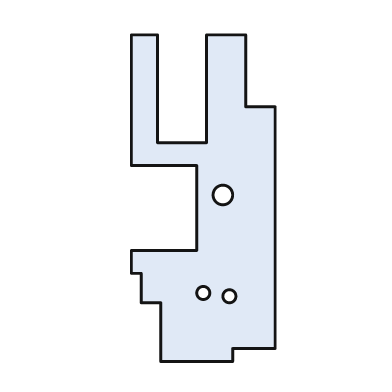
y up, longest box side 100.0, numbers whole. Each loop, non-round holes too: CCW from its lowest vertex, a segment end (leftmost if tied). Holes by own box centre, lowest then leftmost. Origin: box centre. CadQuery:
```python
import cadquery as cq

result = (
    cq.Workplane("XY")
    .moveTo(-13.0, -50.0)
    .lineTo(9.0, -50.0)
    .lineTo(9.0, -46.0)
    .lineTo(22.0, -46.0)
    .lineTo(22.0, 28.0)
    .lineTo(13.0, 28.0)
    .lineTo(13.0, 50.0)
    .lineTo(1.0, 50.0)
    .lineTo(1.0, 17.0)
    .lineTo(-14.0, 17.0)
    .lineTo(-14.0, 50.0)
    .lineTo(-22.0, 50.0)
    .lineTo(-22.0, 10.0)
    .lineTo(-2.0, 10.0)
    .lineTo(-2.0, -16.0)
    .lineTo(-22.0, -16.0)
    .lineTo(-22.0, -23.0)
    .lineTo(-19.0, -23.0)
    .lineTo(-19.0, -32.0)
    .lineTo(-13.0, -32.0)
    .close()
    .moveTo(8.0, -30.0)
    .circle(2.0)
    .moveTo(0.0, -29.0)
    .circle(2.0)
    .moveTo(6.0, 1.0)
    .circle(3.0)
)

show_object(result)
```